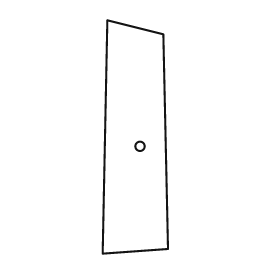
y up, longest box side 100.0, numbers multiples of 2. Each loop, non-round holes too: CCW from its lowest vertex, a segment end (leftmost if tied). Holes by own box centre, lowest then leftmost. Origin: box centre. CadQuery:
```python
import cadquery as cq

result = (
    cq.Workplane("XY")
    .moveTo(-14.0, -50.0)
    .lineTo(14.0, -48.0)
    .lineTo(12.0, 44.0)
    .lineTo(-12.0, 50.0)
    .close()
    .moveTo(2.0, -4.0)
    .circle(2.0)
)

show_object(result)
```